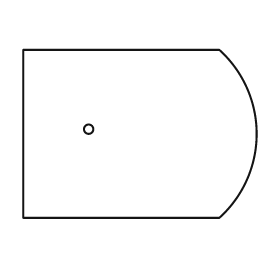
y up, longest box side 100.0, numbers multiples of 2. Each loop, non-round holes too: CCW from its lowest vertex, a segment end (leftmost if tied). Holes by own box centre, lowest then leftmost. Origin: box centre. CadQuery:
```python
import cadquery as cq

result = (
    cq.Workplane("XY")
    .moveTo(-50.0, -36.0)
    .lineTo(34.0, -36.0)
    .threePointArc((50.0, 0.0), (34.0, 36.0))
    .lineTo(-50.0, 36.0)
    .close()
    .moveTo(-22.0, 2.0)
    .circle(2.0)
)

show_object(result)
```